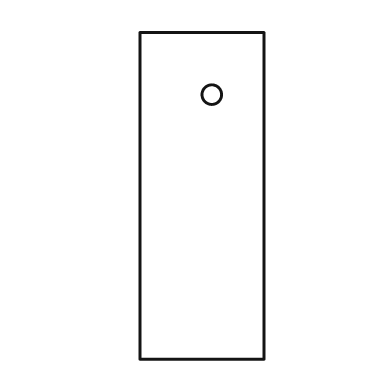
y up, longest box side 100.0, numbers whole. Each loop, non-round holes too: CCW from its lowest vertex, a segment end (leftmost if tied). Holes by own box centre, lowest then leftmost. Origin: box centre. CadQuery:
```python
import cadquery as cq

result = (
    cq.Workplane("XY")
    .moveTo(-19.0, -50.0)
    .lineTo(19.0, -50.0)
    .lineTo(19.0, 50.0)
    .lineTo(-19.0, 50.0)
    .close()
    .moveTo(3.0, 31.0)
    .circle(3.0)
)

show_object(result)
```